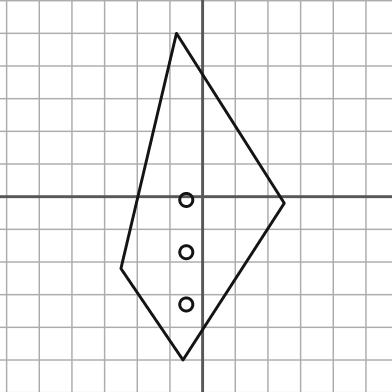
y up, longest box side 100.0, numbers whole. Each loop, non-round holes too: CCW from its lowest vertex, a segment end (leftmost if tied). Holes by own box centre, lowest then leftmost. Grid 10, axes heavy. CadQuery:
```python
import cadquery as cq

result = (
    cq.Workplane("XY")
    .moveTo(-6.0, -50.0)
    .lineTo(25.0, -2.0)
    .lineTo(-8.0, 50.0)
    .lineTo(-25.0, -22.0)
    .close()
    .moveTo(-5.0, -33.0)
    .circle(2.0)
    .moveTo(-5.0, -17.0)
    .circle(2.0)
    .moveTo(-5.0, -1.0)
    .circle(2.0)
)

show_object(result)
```